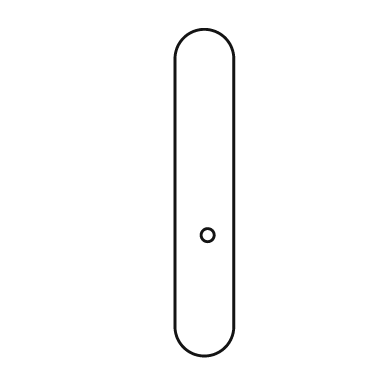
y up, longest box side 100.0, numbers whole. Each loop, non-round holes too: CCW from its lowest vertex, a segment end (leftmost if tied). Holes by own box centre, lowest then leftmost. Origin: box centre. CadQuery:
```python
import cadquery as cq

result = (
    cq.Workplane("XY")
    .moveTo(-9.0, -41.0)
    .threePointArc((0.0, -50.0), (9.0, -41.0))
    .lineTo(9.0, 41.0)
    .threePointArc((0.0, 50.0), (-9.0, 41.0))
    .close()
    .moveTo(1.0, -13.0)
    .circle(2.0)
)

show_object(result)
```